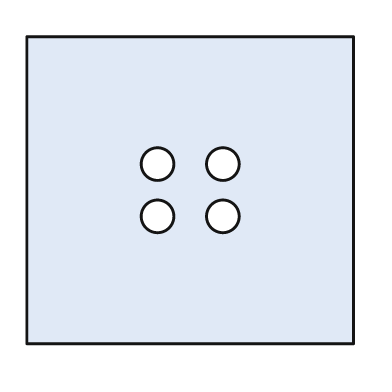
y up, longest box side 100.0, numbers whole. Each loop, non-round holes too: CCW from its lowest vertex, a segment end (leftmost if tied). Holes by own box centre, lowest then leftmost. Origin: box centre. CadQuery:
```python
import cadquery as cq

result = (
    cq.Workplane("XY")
    .moveTo(-50.0, -47.0)
    .lineTo(50.0, -47.0)
    .lineTo(50.0, 47.0)
    .lineTo(-50.0, 47.0)
    .close()
    .moveTo(-10.0, -8.0)
    .circle(5.0)
    .moveTo(10.0, -8.0)
    .circle(5.0)
    .moveTo(-10.0, 8.0)
    .circle(5.0)
    .moveTo(10.0, 8.0)
    .circle(5.0)
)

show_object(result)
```